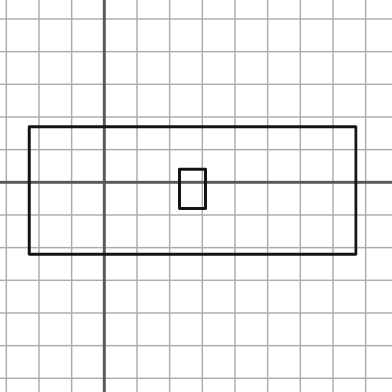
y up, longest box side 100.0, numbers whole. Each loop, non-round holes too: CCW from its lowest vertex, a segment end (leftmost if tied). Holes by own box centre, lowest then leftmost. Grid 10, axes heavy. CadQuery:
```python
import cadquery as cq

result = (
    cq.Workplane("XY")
    .moveTo(-23.0, -22.0)
    .lineTo(77.0, -22.0)
    .lineTo(77.0, 17.0)
    .lineTo(-23.0, 17.0)
    .close()
    .moveTo(23.0, -8.0)
    .lineTo(31.0, -8.0)
    .lineTo(31.0, 4.0)
    .lineTo(23.0, 4.0)
    .close()
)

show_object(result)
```